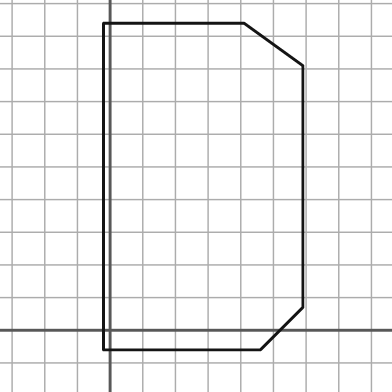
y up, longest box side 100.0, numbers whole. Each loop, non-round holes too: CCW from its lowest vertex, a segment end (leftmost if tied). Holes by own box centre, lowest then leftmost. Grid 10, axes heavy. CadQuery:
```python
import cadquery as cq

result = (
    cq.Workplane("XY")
    .moveTo(-2.0, -6.0)
    .lineTo(46.0, -6.0)
    .lineTo(59.0, 7.0)
    .lineTo(59.0, 81.0)
    .lineTo(41.0, 94.0)
    .lineTo(-2.0, 94.0)
    .close()
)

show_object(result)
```